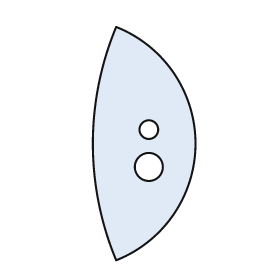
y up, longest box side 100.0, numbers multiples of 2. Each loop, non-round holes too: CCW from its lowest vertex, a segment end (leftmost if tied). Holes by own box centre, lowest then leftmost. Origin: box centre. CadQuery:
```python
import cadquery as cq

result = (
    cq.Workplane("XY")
    .moveTo(-12.0, -50.0)
    .threePointArc((22.0, 0.0), (-12.0, 50.0))
    .threePointArc((-22.0, 0.0), (-12.0, -50.0))
    .close()
    .moveTo(2.0, -10.0)
    .circle(6.0)
    .moveTo(2.0, 6.0)
    .circle(4.0)
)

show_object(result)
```